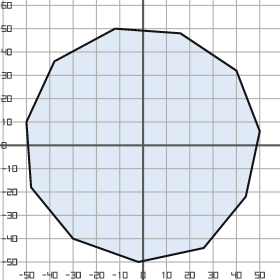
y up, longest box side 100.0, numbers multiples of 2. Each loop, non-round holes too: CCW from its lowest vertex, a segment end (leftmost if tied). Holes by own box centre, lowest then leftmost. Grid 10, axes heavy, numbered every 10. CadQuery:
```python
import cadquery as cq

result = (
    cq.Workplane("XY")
    .moveTo(-2.0, -50.0)
    .lineTo(26.0, -44.0)
    .lineTo(44.0, -22.0)
    .lineTo(50.0, 6.0)
    .lineTo(40.0, 32.0)
    .lineTo(16.0, 48.0)
    .lineTo(-12.0, 50.0)
    .lineTo(-38.0, 36.0)
    .lineTo(-50.0, 10.0)
    .lineTo(-48.0, -18.0)
    .lineTo(-30.0, -40.0)
    .close()
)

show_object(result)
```